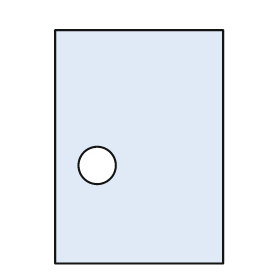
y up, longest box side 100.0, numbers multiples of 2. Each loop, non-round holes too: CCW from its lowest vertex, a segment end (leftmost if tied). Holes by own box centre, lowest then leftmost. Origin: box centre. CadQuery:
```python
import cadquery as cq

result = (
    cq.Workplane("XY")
    .moveTo(-36.0, -50.0)
    .lineTo(36.0, -50.0)
    .lineTo(36.0, 50.0)
    .lineTo(-36.0, 50.0)
    .close()
    .moveTo(-18.0, -8.0)
    .circle(8.0)
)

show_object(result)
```